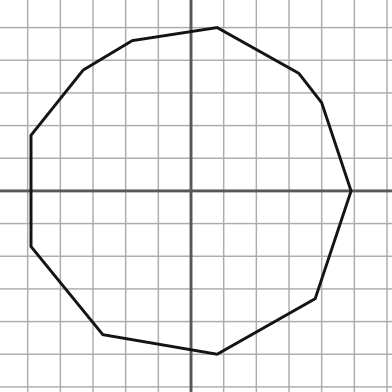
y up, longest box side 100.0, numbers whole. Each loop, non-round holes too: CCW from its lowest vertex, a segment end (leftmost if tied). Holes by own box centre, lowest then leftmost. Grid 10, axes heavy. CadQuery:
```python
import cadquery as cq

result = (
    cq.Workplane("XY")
    .moveTo(8.0, -50.0)
    .lineTo(38.0, -33.0)
    .lineTo(49.0, 0.0)
    .lineTo(40.0, 27.0)
    .lineTo(33.0, 36.0)
    .lineTo(8.0, 50.0)
    .lineTo(-18.0, 46.0)
    .lineTo(-33.0, 37.0)
    .lineTo(-49.0, 17.0)
    .lineTo(-49.0, -17.0)
    .lineTo(-27.0, -44.0)
    .close()
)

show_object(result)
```